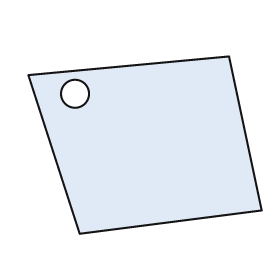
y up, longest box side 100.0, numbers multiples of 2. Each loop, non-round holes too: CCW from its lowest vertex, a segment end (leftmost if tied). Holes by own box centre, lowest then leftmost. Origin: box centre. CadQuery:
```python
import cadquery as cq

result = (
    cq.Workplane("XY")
    .moveTo(-28.0, -38.0)
    .lineTo(50.0, -28.0)
    .lineTo(36.0, 38.0)
    .lineTo(-50.0, 30.0)
    .close()
    .moveTo(-30.0, 22.0)
    .circle(6.0)
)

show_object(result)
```